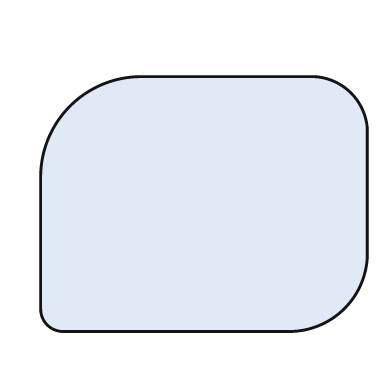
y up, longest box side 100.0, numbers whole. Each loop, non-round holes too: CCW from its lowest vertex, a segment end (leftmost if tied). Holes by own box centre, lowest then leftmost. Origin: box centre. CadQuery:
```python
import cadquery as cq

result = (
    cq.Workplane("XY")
    .moveTo(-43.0, -39.0)
    .lineTo(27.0, -39.0)
    .threePointArc((43.0, -32.0), (50.0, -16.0))
    .lineTo(50.0, 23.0)
    .threePointArc((45.0, 34.0), (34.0, 39.0))
    .lineTo(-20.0, 39.0)
    .threePointArc((-41.0, 30.0), (-50.0, 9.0))
    .lineTo(-50.0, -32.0)
    .threePointArc((-48.0, -37.0), (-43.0, -39.0))
    .close()
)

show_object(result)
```